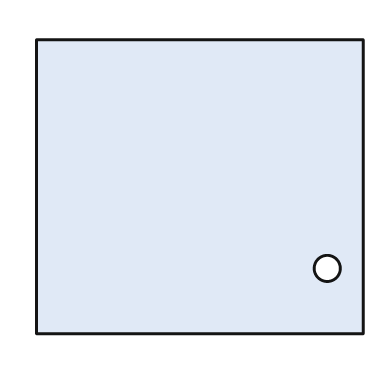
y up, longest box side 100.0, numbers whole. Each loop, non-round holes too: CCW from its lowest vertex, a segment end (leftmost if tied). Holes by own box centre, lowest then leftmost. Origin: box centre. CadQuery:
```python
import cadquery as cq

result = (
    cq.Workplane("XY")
    .moveTo(-50.0, -45.0)
    .lineTo(50.0, -45.0)
    .lineTo(50.0, 45.0)
    .lineTo(-50.0, 45.0)
    .close()
    .moveTo(39.0, -25.0)
    .circle(4.0)
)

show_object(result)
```